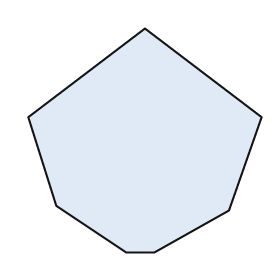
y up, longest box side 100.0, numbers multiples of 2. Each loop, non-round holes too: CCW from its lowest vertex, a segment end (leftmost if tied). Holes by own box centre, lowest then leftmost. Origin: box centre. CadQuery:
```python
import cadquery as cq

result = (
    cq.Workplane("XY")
    .moveTo(-8.0, -48.0)
    .lineTo(4.0, -48.0)
    .lineTo(36.0, -30.0)
    .lineTo(50.0, 10.0)
    .lineTo(0.0, 48.0)
    .lineTo(-50.0, 10.0)
    .lineTo(-38.0, -28.0)
    .close()
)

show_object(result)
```